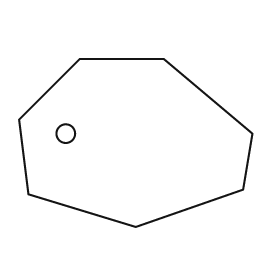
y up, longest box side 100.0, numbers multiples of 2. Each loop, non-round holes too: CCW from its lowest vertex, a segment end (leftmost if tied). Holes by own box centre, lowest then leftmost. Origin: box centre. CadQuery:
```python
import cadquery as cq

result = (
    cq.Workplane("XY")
    .moveTo(0.0, -36.0)
    .lineTo(46.0, -20.0)
    .lineTo(50.0, 4.0)
    .lineTo(12.0, 36.0)
    .lineTo(-24.0, 36.0)
    .lineTo(-50.0, 10.0)
    .lineTo(-46.0, -22.0)
    .close()
    .moveTo(-30.0, 4.0)
    .circle(4.0)
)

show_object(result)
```